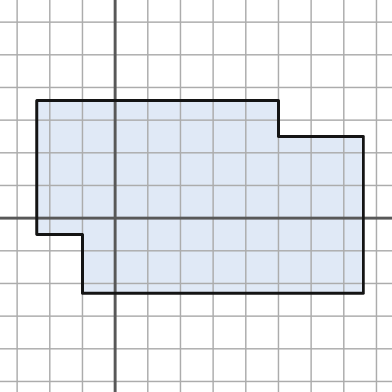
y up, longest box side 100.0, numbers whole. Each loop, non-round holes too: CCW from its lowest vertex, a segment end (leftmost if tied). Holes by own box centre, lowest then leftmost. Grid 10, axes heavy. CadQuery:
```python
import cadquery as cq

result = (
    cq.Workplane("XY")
    .moveTo(-10.0, -23.0)
    .lineTo(76.0, -23.0)
    .lineTo(76.0, 25.0)
    .lineTo(50.0, 25.0)
    .lineTo(50.0, 36.0)
    .lineTo(-24.0, 36.0)
    .lineTo(-24.0, -5.0)
    .lineTo(-10.0, -5.0)
    .close()
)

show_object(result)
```